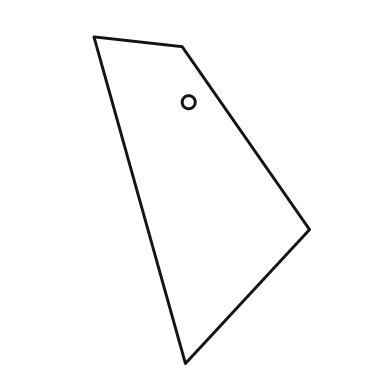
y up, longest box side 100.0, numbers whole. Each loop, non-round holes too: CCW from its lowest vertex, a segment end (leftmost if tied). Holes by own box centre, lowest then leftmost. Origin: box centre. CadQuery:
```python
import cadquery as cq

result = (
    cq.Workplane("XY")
    .moveTo(-5.0, -50.0)
    .lineTo(33.0, -9.0)
    .lineTo(-6.0, 47.0)
    .lineTo(-33.0, 50.0)
    .close()
    .moveTo(-4.0, 30.0)
    .circle(2.0)
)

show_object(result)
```